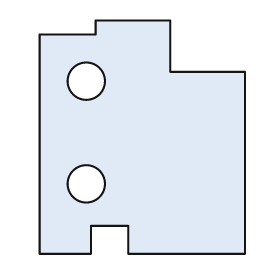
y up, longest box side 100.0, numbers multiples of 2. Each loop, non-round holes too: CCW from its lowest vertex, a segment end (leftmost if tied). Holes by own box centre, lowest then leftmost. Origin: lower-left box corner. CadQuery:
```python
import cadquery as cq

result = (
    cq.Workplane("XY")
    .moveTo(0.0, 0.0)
    .lineTo(22.0, 0.0)
    .lineTo(22.0, 12.0)
    .lineTo(38.0, 12.0)
    .lineTo(38.0, 0.0)
    .lineTo(88.0, 0.0)
    .lineTo(88.0, 78.0)
    .lineTo(56.0, 78.0)
    .lineTo(56.0, 100.0)
    .lineTo(24.0, 100.0)
    .lineTo(24.0, 94.0)
    .lineTo(0.0, 94.0)
    .close()
    .moveTo(20.0, 30.0)
    .circle(8.0)
    .moveTo(20.0, 74.0)
    .circle(8.0)
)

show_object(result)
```